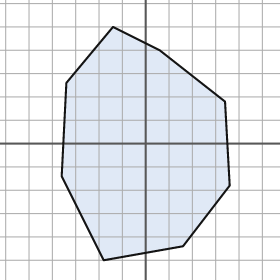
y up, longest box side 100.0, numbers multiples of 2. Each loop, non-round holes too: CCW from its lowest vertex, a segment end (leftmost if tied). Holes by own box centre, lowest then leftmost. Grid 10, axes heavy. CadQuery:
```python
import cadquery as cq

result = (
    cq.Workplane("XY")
    .moveTo(-18.0, -50.0)
    .lineTo(16.0, -44.0)
    .lineTo(36.0, -18.0)
    .lineTo(34.0, 18.0)
    .lineTo(6.0, 40.0)
    .lineTo(-14.0, 50.0)
    .lineTo(-34.0, 26.0)
    .lineTo(-36.0, -14.0)
    .close()
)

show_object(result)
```